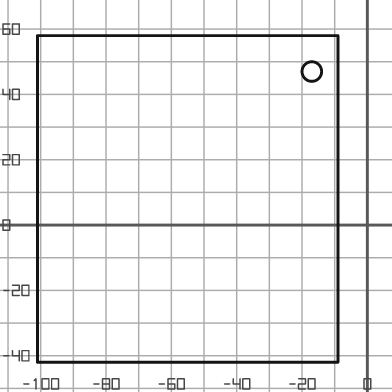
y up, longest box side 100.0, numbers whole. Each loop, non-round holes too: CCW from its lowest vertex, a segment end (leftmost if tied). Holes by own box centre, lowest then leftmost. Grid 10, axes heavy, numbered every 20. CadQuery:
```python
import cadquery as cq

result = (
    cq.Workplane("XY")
    .moveTo(-101.0, -42.0)
    .lineTo(-9.0, -42.0)
    .lineTo(-9.0, 58.0)
    .lineTo(-101.0, 58.0)
    .close()
    .moveTo(-17.0, 47.0)
    .circle(3.0)
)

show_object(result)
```